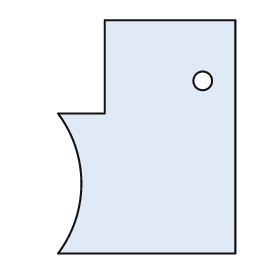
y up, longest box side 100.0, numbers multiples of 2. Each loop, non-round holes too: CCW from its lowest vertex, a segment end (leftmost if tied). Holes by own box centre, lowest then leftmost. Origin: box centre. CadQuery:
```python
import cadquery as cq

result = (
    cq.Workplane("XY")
    .moveTo(-38.0, -50.0)
    .lineTo(38.0, -50.0)
    .lineTo(38.0, 50.0)
    .lineTo(-18.0, 50.0)
    .lineTo(-18.0, 10.0)
    .lineTo(-38.0, 10.0)
    .threePointArc((-28.0, -20.0), (-38.0, -50.0))
    .close()
    .moveTo(24.0, 24.0)
    .circle(4.0)
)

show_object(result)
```